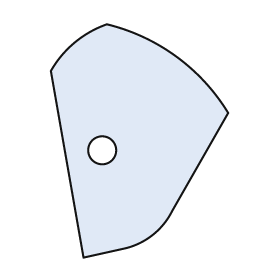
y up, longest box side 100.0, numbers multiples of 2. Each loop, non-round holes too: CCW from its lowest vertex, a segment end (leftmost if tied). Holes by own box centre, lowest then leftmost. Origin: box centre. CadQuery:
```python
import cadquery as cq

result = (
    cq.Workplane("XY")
    .moveTo(-24.0, -50.0)
    .lineTo(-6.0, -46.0)
    .threePointArc((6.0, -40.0), (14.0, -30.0))
    .lineTo(38.0, 12.0)
    .threePointArc((16.0, 36.0), (-14.0, 50.0))
    .threePointArc((-28.0, 42.0), (-38.0, 30.0))
    .close()
    .moveTo(-16.0, -4.0)
    .circle(6.0)
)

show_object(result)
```